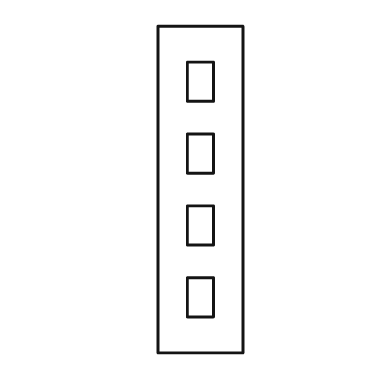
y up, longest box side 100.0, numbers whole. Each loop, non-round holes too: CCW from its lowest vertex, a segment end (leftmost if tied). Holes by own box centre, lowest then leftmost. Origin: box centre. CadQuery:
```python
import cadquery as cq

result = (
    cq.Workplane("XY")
    .moveTo(-13.0, -50.0)
    .lineTo(13.0, -50.0)
    .lineTo(13.0, 50.0)
    .lineTo(-13.0, 50.0)
    .close()
    .moveTo(-4.0, -39.0)
    .lineTo(4.0, -39.0)
    .lineTo(4.0, -27.0)
    .lineTo(-4.0, -27.0)
    .close()
    .moveTo(-4.0, -17.0)
    .lineTo(4.0, -17.0)
    .lineTo(4.0, -5.0)
    .lineTo(-4.0, -5.0)
    .close()
    .moveTo(-4.0, 5.0)
    .lineTo(4.0, 5.0)
    .lineTo(4.0, 17.0)
    .lineTo(-4.0, 17.0)
    .close()
    .moveTo(-4.0, 27.0)
    .lineTo(4.0, 27.0)
    .lineTo(4.0, 39.0)
    .lineTo(-4.0, 39.0)
    .close()
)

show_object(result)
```